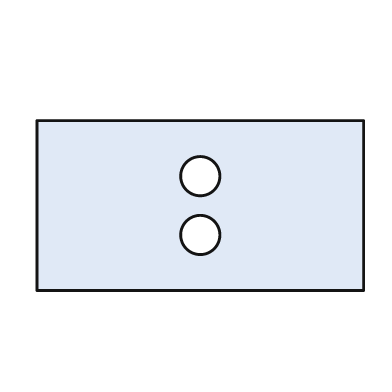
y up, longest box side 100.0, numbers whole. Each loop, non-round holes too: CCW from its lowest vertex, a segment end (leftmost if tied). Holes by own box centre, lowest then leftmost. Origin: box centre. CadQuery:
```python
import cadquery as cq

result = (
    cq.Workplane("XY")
    .moveTo(-50.0, -26.0)
    .lineTo(50.0, -26.0)
    .lineTo(50.0, 26.0)
    .lineTo(-50.0, 26.0)
    .close()
    .moveTo(0.0, -9.0)
    .circle(6.0)
    .moveTo(0.0, 9.0)
    .circle(6.0)
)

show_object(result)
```